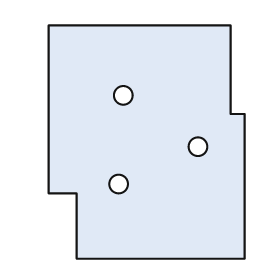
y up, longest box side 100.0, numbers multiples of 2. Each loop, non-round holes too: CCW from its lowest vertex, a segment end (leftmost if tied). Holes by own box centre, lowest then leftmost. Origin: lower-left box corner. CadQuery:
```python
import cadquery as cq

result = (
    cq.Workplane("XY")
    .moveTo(12.0, 0.0)
    .lineTo(84.0, 0.0)
    .lineTo(84.0, 62.0)
    .lineTo(78.0, 62.0)
    .lineTo(78.0, 100.0)
    .lineTo(0.0, 100.0)
    .lineTo(0.0, 28.0)
    .lineTo(12.0, 28.0)
    .close()
    .moveTo(30.0, 32.0)
    .circle(4.0)
    .moveTo(64.0, 48.0)
    .circle(4.0)
    .moveTo(32.0, 70.0)
    .circle(4.0)
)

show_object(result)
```